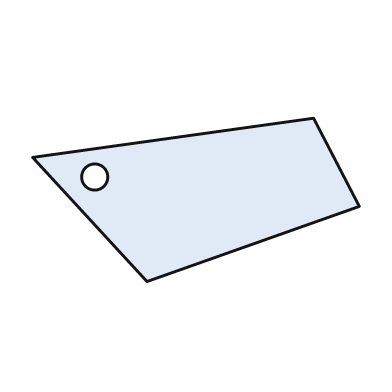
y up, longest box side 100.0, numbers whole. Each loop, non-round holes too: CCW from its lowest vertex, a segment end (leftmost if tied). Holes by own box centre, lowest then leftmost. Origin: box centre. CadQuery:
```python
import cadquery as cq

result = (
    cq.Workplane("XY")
    .moveTo(-15.0, -25.0)
    .lineTo(50.0, -2.0)
    .lineTo(36.0, 25.0)
    .lineTo(-50.0, 13.0)
    .close()
    .moveTo(-31.0, 7.0)
    .circle(4.0)
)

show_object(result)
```